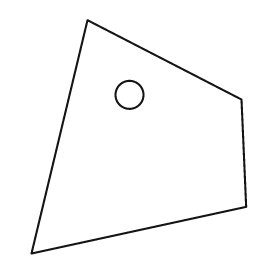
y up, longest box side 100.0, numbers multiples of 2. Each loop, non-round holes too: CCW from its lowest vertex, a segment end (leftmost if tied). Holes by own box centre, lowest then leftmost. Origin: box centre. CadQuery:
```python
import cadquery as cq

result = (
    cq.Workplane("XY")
    .moveTo(-46.0, -50.0)
    .lineTo(46.0, -30.0)
    .lineTo(44.0, 16.0)
    .lineTo(-22.0, 50.0)
    .close()
    .moveTo(-4.0, 18.0)
    .circle(6.0)
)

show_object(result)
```